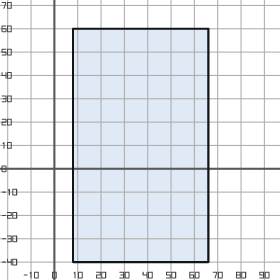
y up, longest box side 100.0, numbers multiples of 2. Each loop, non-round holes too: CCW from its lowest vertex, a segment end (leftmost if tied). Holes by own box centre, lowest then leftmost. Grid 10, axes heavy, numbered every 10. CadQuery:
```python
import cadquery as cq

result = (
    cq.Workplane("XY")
    .moveTo(8.0, -40.0)
    .lineTo(66.0, -40.0)
    .lineTo(66.0, 60.0)
    .lineTo(8.0, 60.0)
    .close()
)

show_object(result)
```